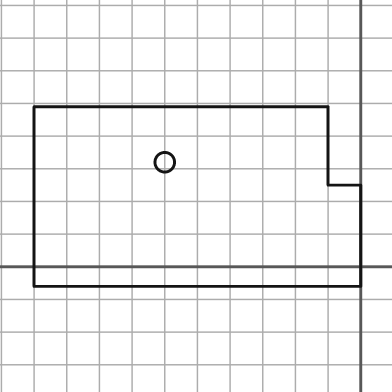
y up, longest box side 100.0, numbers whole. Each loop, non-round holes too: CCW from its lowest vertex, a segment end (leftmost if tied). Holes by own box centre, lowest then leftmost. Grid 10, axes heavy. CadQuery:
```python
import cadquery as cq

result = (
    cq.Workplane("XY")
    .moveTo(-100.0, -6.0)
    .lineTo(0.0, -6.0)
    .lineTo(0.0, 25.0)
    .lineTo(-10.0, 25.0)
    .lineTo(-10.0, 49.0)
    .lineTo(-100.0, 49.0)
    .close()
    .moveTo(-60.0, 32.0)
    .circle(3.0)
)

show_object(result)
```